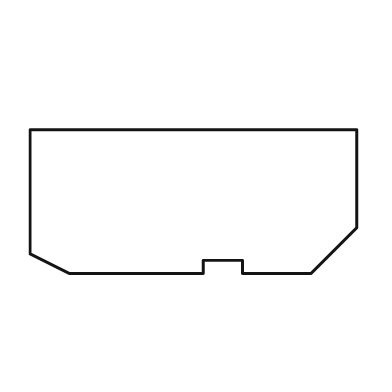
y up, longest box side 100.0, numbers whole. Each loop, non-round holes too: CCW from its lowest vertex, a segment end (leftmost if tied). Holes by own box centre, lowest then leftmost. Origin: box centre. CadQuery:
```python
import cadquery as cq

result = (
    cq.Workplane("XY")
    .moveTo(-38.0, -22.0)
    .lineTo(3.0, -22.0)
    .lineTo(3.0, -18.0)
    .lineTo(15.0, -18.0)
    .lineTo(15.0, -22.0)
    .lineTo(36.0, -22.0)
    .lineTo(50.0, -8.0)
    .lineTo(50.0, 22.0)
    .lineTo(-50.0, 22.0)
    .lineTo(-50.0, -16.0)
    .close()
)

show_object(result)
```